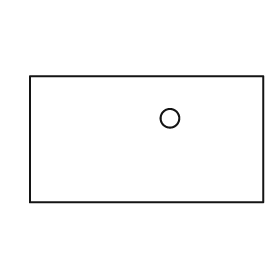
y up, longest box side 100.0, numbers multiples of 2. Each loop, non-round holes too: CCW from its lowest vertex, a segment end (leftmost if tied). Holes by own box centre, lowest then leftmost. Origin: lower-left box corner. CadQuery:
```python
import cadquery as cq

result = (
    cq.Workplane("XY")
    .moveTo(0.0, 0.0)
    .lineTo(100.0, 0.0)
    .lineTo(100.0, 54.0)
    .lineTo(0.0, 54.0)
    .close()
    .moveTo(60.0, 36.0)
    .circle(4.0)
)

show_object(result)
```